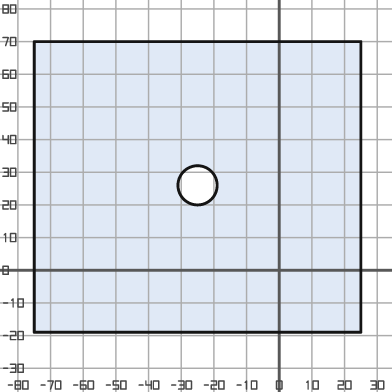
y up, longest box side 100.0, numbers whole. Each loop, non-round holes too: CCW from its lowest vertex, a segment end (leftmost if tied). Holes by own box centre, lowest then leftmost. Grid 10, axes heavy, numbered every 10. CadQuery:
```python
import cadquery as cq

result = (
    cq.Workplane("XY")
    .moveTo(-75.0, -19.0)
    .lineTo(25.0, -19.0)
    .lineTo(25.0, 70.0)
    .lineTo(-75.0, 70.0)
    .close()
    .moveTo(-25.0, 26.0)
    .circle(6.0)
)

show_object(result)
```